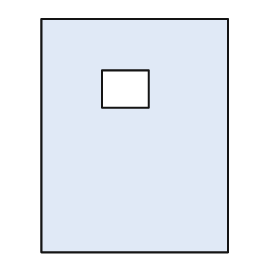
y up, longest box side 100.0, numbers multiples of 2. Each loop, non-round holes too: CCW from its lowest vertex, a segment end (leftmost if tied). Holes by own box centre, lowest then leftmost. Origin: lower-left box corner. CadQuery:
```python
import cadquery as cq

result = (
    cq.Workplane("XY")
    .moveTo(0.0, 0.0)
    .lineTo(80.0, 0.0)
    .lineTo(80.0, 100.0)
    .lineTo(0.0, 100.0)
    .close()
    .moveTo(26.0, 62.0)
    .lineTo(46.0, 62.0)
    .lineTo(46.0, 78.0)
    .lineTo(26.0, 78.0)
    .close()
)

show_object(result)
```